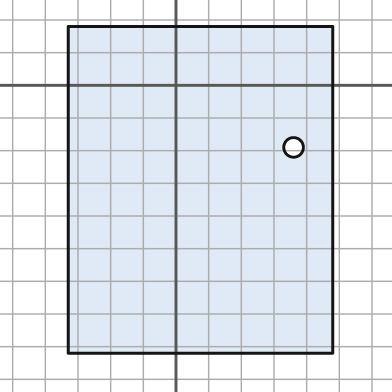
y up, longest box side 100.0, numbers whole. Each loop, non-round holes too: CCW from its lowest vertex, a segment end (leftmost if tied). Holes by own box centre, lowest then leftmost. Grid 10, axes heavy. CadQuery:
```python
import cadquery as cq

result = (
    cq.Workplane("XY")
    .moveTo(-33.0, -82.0)
    .lineTo(48.0, -82.0)
    .lineTo(48.0, 18.0)
    .lineTo(-33.0, 18.0)
    .close()
    .moveTo(36.0, -19.0)
    .circle(3.0)
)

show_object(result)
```